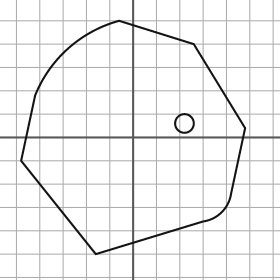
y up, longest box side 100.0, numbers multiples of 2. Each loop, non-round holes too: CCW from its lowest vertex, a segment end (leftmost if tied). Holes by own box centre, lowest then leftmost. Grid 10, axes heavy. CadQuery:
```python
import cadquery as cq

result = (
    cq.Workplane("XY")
    .moveTo(-16.0, -50.0)
    .lineTo(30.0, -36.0)
    .threePointArc((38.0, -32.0), (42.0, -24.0))
    .lineTo(48.0, 4.0)
    .lineTo(26.0, 40.0)
    .lineTo(-6.0, 50.0)
    .threePointArc((-28.0, 38.0), (-42.0, 18.0))
    .lineTo(-48.0, -10.0)
    .close()
    .moveTo(22.0, 6.0)
    .circle(4.0)
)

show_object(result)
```